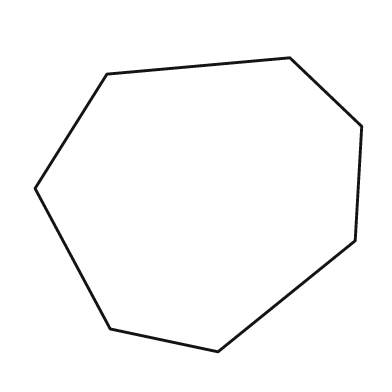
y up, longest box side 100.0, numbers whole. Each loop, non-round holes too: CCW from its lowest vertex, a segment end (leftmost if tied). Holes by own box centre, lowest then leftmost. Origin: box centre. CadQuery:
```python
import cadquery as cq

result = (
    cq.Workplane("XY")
    .moveTo(6.0, -45.0)
    .lineTo(48.0, -11.0)
    .lineTo(50.0, 24.0)
    .lineTo(28.0, 45.0)
    .lineTo(-28.0, 40.0)
    .lineTo(-50.0, 5.0)
    .lineTo(-27.0, -38.0)
    .close()
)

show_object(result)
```